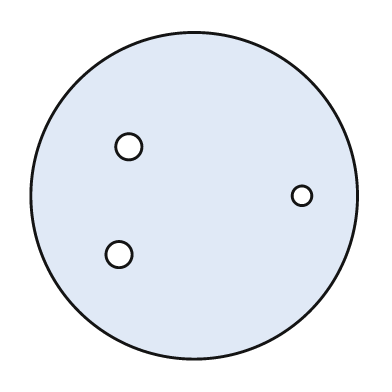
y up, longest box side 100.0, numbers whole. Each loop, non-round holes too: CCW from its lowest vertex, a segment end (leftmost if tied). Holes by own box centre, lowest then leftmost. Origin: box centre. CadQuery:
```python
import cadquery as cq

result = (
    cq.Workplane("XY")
    .moveTo(0.0, 0.0)
    .circle(50.0)
    .moveTo(-23.0, -18.0)
    .circle(4.0)
    .moveTo(33.0, 0.0)
    .circle(3.0)
    .moveTo(-20.0, 15.0)
    .circle(4.0)
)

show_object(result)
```